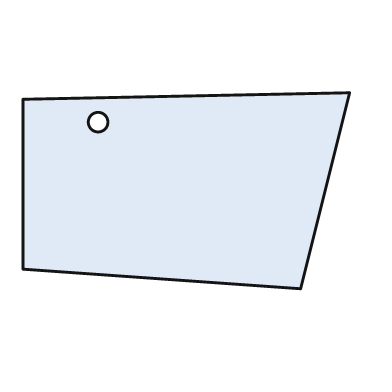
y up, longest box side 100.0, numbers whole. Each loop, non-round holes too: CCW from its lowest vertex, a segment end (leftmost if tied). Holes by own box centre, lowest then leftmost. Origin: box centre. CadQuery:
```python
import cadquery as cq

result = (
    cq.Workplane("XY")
    .moveTo(35.0, -30.0)
    .lineTo(50.0, 30.0)
    .lineTo(-50.0, 28.0)
    .lineTo(-50.0, -24.0)
    .close()
    .moveTo(-27.0, 21.0)
    .circle(3.0)
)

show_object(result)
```